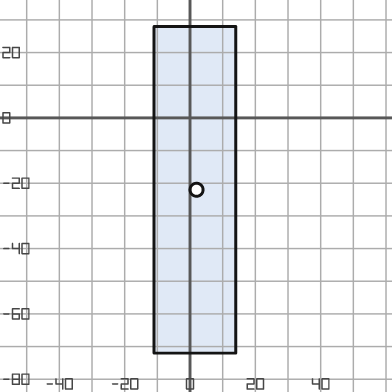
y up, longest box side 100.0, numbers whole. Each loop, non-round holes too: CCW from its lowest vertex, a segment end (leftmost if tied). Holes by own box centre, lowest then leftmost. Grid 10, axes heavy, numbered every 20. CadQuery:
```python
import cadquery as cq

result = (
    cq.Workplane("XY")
    .moveTo(-11.0, -72.0)
    .lineTo(14.0, -72.0)
    .lineTo(14.0, 28.0)
    .lineTo(-11.0, 28.0)
    .close()
    .moveTo(2.0, -22.0)
    .circle(2.0)
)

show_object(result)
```